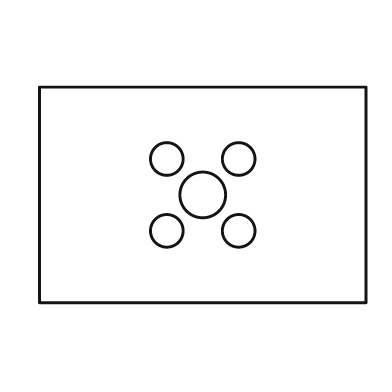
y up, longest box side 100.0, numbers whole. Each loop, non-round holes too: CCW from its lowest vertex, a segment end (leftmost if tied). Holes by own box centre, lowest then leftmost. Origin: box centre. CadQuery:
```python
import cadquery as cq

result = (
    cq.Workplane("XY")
    .moveTo(-50.0, -33.0)
    .lineTo(50.0, -33.0)
    .lineTo(50.0, 33.0)
    .lineTo(-50.0, 33.0)
    .close()
    .moveTo(-11.0, -11.0)
    .circle(5.0)
    .moveTo(11.0, -11.0)
    .circle(5.0)
    .moveTo(0.0, 0.0)
    .circle(7.0)
    .moveTo(-11.0, 11.0)
    .circle(5.0)
    .moveTo(11.0, 11.0)
    .circle(5.0)
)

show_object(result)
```